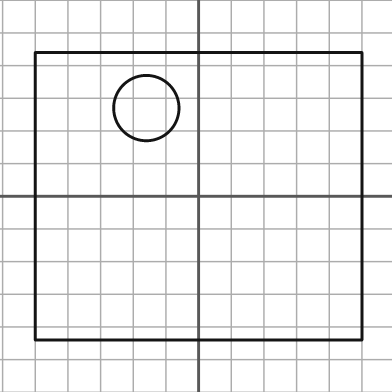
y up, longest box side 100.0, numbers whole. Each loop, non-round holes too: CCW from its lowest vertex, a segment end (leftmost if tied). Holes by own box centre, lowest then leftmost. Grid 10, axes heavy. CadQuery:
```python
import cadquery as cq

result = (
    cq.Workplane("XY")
    .moveTo(-50.0, -44.0)
    .lineTo(50.0, -44.0)
    .lineTo(50.0, 44.0)
    .lineTo(-50.0, 44.0)
    .close()
    .moveTo(-16.0, 27.0)
    .circle(10.0)
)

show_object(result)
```